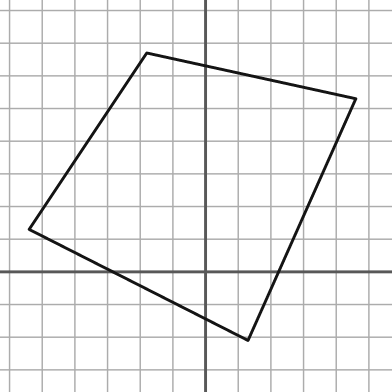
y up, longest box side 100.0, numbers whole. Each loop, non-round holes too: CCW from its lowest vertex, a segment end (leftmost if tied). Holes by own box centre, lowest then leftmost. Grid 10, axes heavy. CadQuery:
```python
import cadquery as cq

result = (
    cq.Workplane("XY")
    .moveTo(13.0, -21.0)
    .lineTo(46.0, 53.0)
    .lineTo(-18.0, 67.0)
    .lineTo(-54.0, 13.0)
    .close()
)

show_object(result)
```